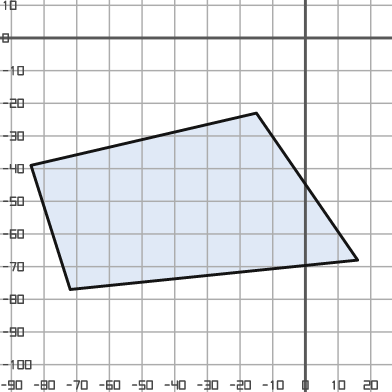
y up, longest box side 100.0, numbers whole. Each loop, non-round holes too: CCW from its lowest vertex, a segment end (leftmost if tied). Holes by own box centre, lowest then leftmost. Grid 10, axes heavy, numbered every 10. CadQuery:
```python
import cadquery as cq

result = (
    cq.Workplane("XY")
    .moveTo(-72.0, -77.0)
    .lineTo(16.0, -68.0)
    .lineTo(-15.0, -23.0)
    .lineTo(-84.0, -39.0)
    .close()
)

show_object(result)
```